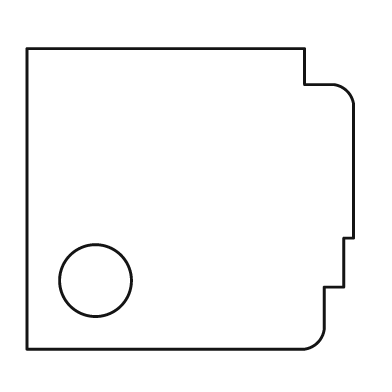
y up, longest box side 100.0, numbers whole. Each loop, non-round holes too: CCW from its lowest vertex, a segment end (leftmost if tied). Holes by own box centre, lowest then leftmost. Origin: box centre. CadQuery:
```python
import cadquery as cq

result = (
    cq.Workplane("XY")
    .moveTo(-50.0, -46.0)
    .lineTo(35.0, -46.0)
    .threePointArc((39.0, -44.0), (41.0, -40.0))
    .lineTo(41.0, -27.0)
    .lineTo(47.0, -27.0)
    .lineTo(47.0, -12.0)
    .lineTo(50.0, -12.0)
    .lineTo(50.0, 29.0)
    .threePointArc((48.0, 33.0), (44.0, 35.0))
    .lineTo(35.0, 35.0)
    .lineTo(35.0, 46.0)
    .lineTo(-50.0, 46.0)
    .close()
    .moveTo(-29.0, -25.0)
    .circle(11.0)
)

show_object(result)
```